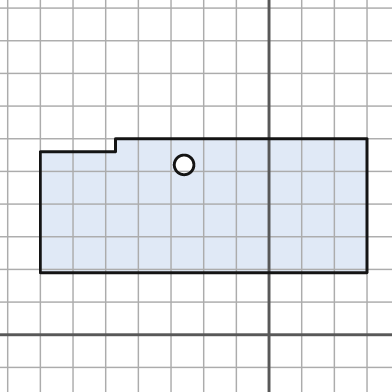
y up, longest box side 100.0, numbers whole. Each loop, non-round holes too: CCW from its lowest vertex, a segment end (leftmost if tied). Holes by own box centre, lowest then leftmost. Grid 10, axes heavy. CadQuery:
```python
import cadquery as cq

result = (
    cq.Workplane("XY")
    .moveTo(-70.0, 19.0)
    .lineTo(30.0, 19.0)
    .lineTo(30.0, 60.0)
    .lineTo(-47.0, 60.0)
    .lineTo(-47.0, 56.0)
    .lineTo(-70.0, 56.0)
    .close()
    .moveTo(-26.0, 52.0)
    .circle(3.0)
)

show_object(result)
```